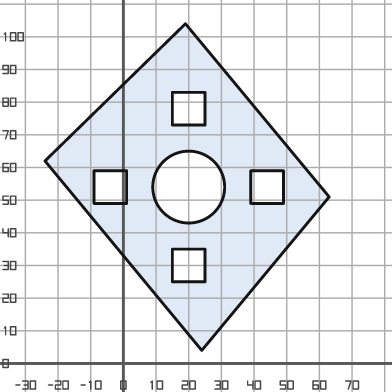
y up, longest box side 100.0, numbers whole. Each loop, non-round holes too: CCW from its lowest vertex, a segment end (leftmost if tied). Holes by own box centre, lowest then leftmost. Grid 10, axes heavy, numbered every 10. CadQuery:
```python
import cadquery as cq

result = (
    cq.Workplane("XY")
    .moveTo(24.0, 4.0)
    .lineTo(63.0, 51.0)
    .lineTo(19.0, 104.0)
    .lineTo(-24.0, 62.0)
    .close()
    .moveTo(15.0, 25.0)
    .lineTo(25.0, 25.0)
    .lineTo(25.0, 35.0)
    .lineTo(15.0, 35.0)
    .close()
    .moveTo(-9.0, 49.0)
    .lineTo(1.0, 49.0)
    .lineTo(1.0, 59.0)
    .lineTo(-9.0, 59.0)
    .close()
    .moveTo(20.0, 54.0)
    .circle(11.0)
    .moveTo(39.0, 49.0)
    .lineTo(49.0, 49.0)
    .lineTo(49.0, 59.0)
    .lineTo(39.0, 59.0)
    .close()
    .moveTo(15.0, 73.0)
    .lineTo(25.0, 73.0)
    .lineTo(25.0, 83.0)
    .lineTo(15.0, 83.0)
    .close()
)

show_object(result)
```